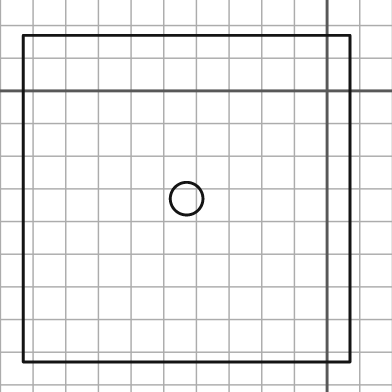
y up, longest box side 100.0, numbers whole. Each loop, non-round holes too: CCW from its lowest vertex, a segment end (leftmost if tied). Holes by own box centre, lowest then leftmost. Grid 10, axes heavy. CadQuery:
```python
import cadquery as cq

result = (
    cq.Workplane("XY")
    .moveTo(-93.0, -83.0)
    .lineTo(7.0, -83.0)
    .lineTo(7.0, 17.0)
    .lineTo(-93.0, 17.0)
    .close()
    .moveTo(-43.0, -33.0)
    .circle(5.0)
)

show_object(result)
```